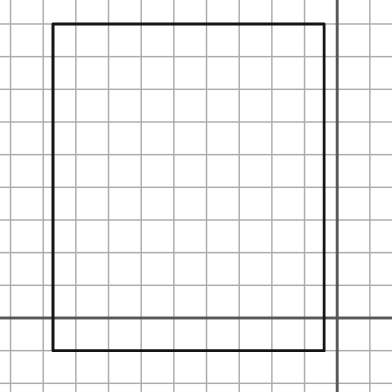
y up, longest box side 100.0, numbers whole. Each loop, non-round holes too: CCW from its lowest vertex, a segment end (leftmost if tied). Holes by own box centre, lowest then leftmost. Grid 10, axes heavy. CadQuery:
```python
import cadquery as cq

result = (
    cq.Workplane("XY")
    .moveTo(-87.0, -10.0)
    .lineTo(-4.0, -10.0)
    .lineTo(-4.0, 90.0)
    .lineTo(-87.0, 90.0)
    .close()
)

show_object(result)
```